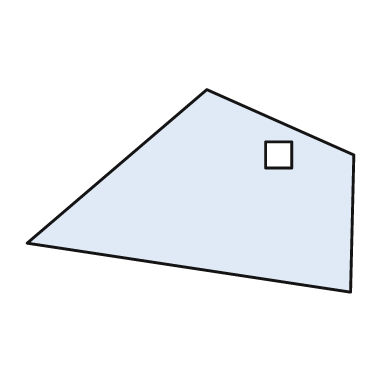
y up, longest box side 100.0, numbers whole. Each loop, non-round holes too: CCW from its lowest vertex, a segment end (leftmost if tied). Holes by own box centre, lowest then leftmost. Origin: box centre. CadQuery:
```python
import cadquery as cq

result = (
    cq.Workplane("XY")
    .moveTo(49.0, -31.0)
    .lineTo(50.0, 11.0)
    .lineTo(5.0, 31.0)
    .lineTo(-50.0, -16.0)
    .close()
    .moveTo(23.0, 7.0)
    .lineTo(31.0, 7.0)
    .lineTo(31.0, 15.0)
    .lineTo(23.0, 15.0)
    .close()
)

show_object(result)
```